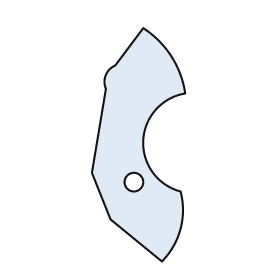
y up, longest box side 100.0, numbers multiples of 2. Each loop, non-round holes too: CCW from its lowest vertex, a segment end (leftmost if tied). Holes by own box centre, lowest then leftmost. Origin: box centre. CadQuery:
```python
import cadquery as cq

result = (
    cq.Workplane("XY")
    .moveTo(10.0, -50.0)
    .threePointArc((18.0, -36.0), (18.0, -20.0))
    .threePointArc((2.0, 2.0), (20.0, 22.0))
    .threePointArc((14.0, 38.0), (2.0, 50.0))
    .lineTo(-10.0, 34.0)
    .threePointArc((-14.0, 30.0), (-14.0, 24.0))
    .lineTo(-20.0, -12.0)
    .lineTo(-12.0, -32.0)
    .close()
    .moveTo(-2.0, -16.0)
    .circle(4.0)
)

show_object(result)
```